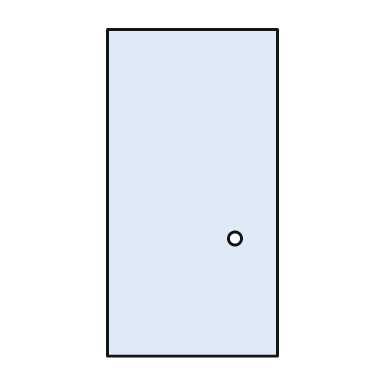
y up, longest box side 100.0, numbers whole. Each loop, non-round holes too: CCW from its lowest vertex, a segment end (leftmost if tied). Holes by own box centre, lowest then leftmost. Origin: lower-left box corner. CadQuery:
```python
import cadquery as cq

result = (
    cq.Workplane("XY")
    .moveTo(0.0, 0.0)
    .lineTo(52.0, 0.0)
    .lineTo(52.0, 100.0)
    .lineTo(0.0, 100.0)
    .close()
    .moveTo(39.0, 36.0)
    .circle(2.0)
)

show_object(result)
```